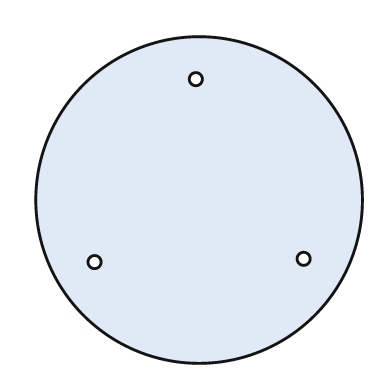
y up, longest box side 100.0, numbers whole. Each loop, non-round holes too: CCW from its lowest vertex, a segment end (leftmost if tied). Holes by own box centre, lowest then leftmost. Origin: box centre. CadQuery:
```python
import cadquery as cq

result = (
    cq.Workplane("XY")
    .moveTo(0.0, 0.0)
    .circle(50.0)
    .moveTo(-32.0, -19.0)
    .circle(2.0)
    .moveTo(32.0, -18.0)
    .circle(2.0)
    .moveTo(-1.0, 37.0)
    .circle(2.0)
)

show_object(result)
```